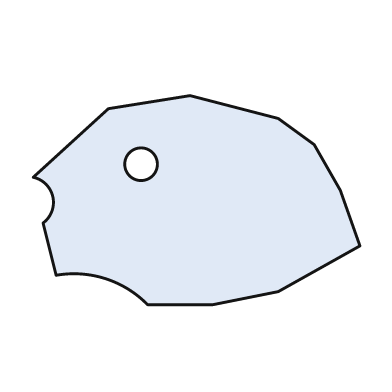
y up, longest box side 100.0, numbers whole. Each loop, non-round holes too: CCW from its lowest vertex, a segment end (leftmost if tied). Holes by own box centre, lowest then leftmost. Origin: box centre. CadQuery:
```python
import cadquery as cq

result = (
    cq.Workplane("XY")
    .moveTo(-15.0, -32.0)
    .lineTo(5.0, -32.0)
    .lineTo(25.0, -28.0)
    .lineTo(50.0, -14.0)
    .lineTo(44.0, 3.0)
    .lineTo(36.0, 17.0)
    .lineTo(25.0, 25.0)
    .lineTo(-2.0, 32.0)
    .lineTo(-27.0, 28.0)
    .lineTo(-50.0, 7.0)
    .threePointArc((-44.0, 1.0), (-47.0, -7.0))
    .lineTo(-43.0, -23.0)
    .threePointArc((-28.0, -24.0), (-15.0, -32.0))
    .close()
    .moveTo(-17.0, 11.0)
    .circle(5.0)
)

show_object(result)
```